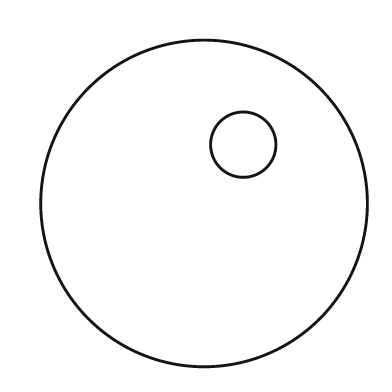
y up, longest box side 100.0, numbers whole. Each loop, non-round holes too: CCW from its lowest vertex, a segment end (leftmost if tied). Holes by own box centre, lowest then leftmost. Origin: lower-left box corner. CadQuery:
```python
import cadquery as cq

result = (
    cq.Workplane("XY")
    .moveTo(50.0, 50.0)
    .circle(50.0)
    .moveTo(62.0, 68.0)
    .circle(10.0)
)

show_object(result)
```